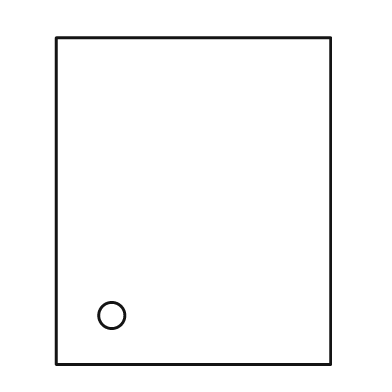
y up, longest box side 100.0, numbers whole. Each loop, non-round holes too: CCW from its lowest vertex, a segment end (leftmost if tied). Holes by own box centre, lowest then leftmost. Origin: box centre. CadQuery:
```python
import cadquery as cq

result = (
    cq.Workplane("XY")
    .moveTo(-42.0, -50.0)
    .lineTo(42.0, -50.0)
    .lineTo(42.0, 50.0)
    .lineTo(-42.0, 50.0)
    .close()
    .moveTo(-25.0, -35.0)
    .circle(4.0)
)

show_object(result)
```